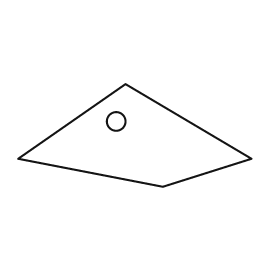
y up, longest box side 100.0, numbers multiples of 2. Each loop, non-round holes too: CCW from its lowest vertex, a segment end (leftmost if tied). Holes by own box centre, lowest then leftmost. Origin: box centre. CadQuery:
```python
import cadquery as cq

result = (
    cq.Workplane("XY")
    .moveTo(12.0, -22.0)
    .lineTo(50.0, -10.0)
    .lineTo(-4.0, 22.0)
    .lineTo(-50.0, -10.0)
    .close()
    .moveTo(-8.0, 6.0)
    .circle(4.0)
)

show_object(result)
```